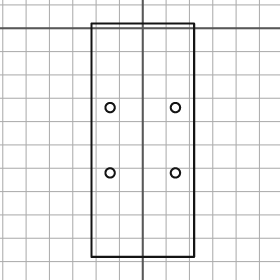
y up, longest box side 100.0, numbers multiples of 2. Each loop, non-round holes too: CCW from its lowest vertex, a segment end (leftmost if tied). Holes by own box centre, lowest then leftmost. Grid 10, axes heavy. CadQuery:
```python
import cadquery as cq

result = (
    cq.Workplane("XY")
    .moveTo(-22.0, -98.0)
    .lineTo(22.0, -98.0)
    .lineTo(22.0, 2.0)
    .lineTo(-22.0, 2.0)
    .close()
    .moveTo(-14.0, -62.0)
    .circle(2.0)
    .moveTo(14.0, -62.0)
    .circle(2.0)
    .moveTo(-14.0, -34.0)
    .circle(2.0)
    .moveTo(14.0, -34.0)
    .circle(2.0)
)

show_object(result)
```